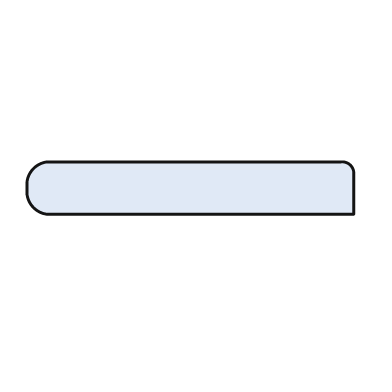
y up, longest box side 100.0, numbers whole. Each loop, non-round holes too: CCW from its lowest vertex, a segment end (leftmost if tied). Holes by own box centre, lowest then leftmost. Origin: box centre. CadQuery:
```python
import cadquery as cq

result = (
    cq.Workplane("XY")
    .moveTo(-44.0, -8.0)
    .lineTo(50.0, -8.0)
    .lineTo(50.0, 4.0)
    .threePointArc((49.0, 7.0), (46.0, 8.0))
    .lineTo(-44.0, 8.0)
    .threePointArc((-48.0, 6.0), (-50.0, 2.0))
    .lineTo(-50.0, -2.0)
    .threePointArc((-48.0, -6.0), (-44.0, -8.0))
    .close()
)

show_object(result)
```